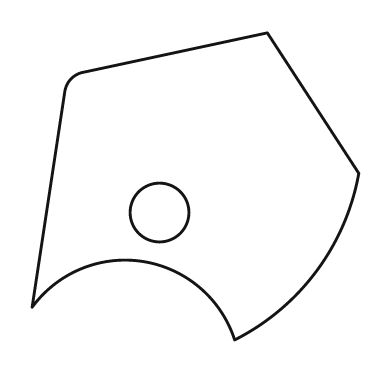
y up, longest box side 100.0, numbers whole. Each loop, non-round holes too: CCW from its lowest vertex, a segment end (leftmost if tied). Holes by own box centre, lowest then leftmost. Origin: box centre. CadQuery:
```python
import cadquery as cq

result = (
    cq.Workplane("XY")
    .moveTo(12.0, -47.0)
    .threePointArc((37.0, -26.0), (50.0, 4.0))
    .lineTo(22.0, 47.0)
    .lineTo(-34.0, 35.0)
    .threePointArc((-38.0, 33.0), (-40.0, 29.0))
    .lineTo(-50.0, -37.0)
    .threePointArc((-16.0, -23.0), (12.0, -47.0))
    .close()
    .moveTo(-11.0, -8.0)
    .circle(9.0)
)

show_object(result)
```